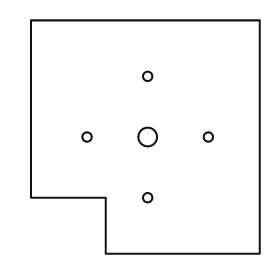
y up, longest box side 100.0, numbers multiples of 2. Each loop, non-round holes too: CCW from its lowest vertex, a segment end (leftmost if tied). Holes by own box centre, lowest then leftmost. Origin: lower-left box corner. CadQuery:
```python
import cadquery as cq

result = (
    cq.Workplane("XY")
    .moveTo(32.0, 0.0)
    .lineTo(98.0, 0.0)
    .lineTo(98.0, 100.0)
    .lineTo(0.0, 100.0)
    .lineTo(0.0, 24.0)
    .lineTo(32.0, 24.0)
    .close()
    .moveTo(50.0, 24.0)
    .circle(2.0)
    .moveTo(24.0, 50.0)
    .circle(2.0)
    .moveTo(50.0, 50.0)
    .circle(4.0)
    .moveTo(76.0, 50.0)
    .circle(2.0)
    .moveTo(50.0, 76.0)
    .circle(2.0)
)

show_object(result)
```